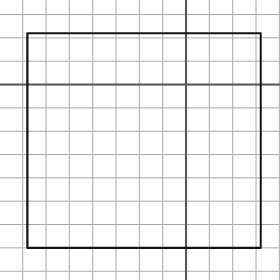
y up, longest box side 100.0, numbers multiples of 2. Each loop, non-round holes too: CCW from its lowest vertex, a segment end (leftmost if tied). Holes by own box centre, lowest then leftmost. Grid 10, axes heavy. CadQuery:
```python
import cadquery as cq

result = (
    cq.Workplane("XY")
    .moveTo(-68.0, -70.0)
    .lineTo(32.0, -70.0)
    .lineTo(32.0, 22.0)
    .lineTo(-68.0, 22.0)
    .close()
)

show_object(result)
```